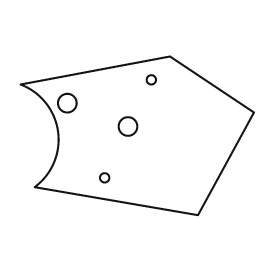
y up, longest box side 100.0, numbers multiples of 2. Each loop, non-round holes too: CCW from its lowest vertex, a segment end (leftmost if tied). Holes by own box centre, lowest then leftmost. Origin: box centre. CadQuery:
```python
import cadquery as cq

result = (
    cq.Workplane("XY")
    .moveTo(26.0, -34.0)
    .lineTo(50.0, 10.0)
    .lineTo(14.0, 34.0)
    .lineTo(-50.0, 22.0)
    .threePointArc((-34.0, 2.0), (-44.0, -22.0))
    .close()
    .moveTo(-14.0, -18.0)
    .circle(2.0)
    .moveTo(-4.0, 4.0)
    .circle(4.0)
    .moveTo(-30.0, 14.0)
    .circle(4.0)
    .moveTo(6.0, 24.0)
    .circle(2.0)
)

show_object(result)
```